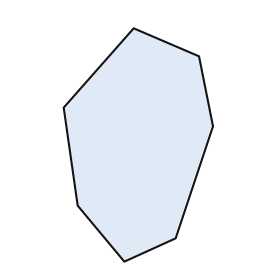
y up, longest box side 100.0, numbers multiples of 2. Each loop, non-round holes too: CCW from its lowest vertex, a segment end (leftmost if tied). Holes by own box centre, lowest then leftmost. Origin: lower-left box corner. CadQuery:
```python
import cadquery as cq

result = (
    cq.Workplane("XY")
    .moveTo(26.0, 0.0)
    .lineTo(48.0, 10.0)
    .lineTo(64.0, 58.0)
    .lineTo(58.0, 88.0)
    .lineTo(30.0, 100.0)
    .lineTo(0.0, 66.0)
    .lineTo(6.0, 24.0)
    .close()
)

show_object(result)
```